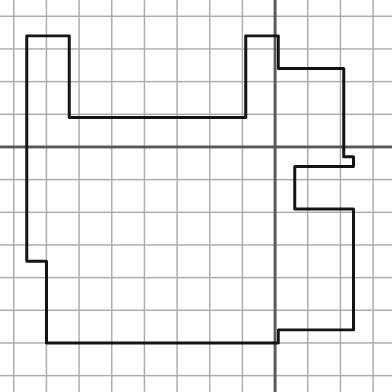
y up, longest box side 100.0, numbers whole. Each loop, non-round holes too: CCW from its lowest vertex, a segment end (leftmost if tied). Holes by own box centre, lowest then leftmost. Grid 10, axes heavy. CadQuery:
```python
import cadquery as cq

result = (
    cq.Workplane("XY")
    .moveTo(-70.0, -60.0)
    .lineTo(1.0, -60.0)
    .lineTo(1.0, -56.0)
    .lineTo(24.0, -56.0)
    .lineTo(24.0, -19.0)
    .lineTo(6.0, -19.0)
    .lineTo(6.0, -6.0)
    .lineTo(24.0, -6.0)
    .lineTo(24.0, -3.0)
    .lineTo(21.0, -3.0)
    .lineTo(21.0, 24.0)
    .lineTo(1.0, 24.0)
    .lineTo(1.0, 34.0)
    .lineTo(-9.0, 34.0)
    .lineTo(-9.0, 9.0)
    .lineTo(-63.0, 9.0)
    .lineTo(-63.0, 34.0)
    .lineTo(-76.0, 34.0)
    .lineTo(-76.0, -35.0)
    .lineTo(-70.0, -35.0)
    .close()
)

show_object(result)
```